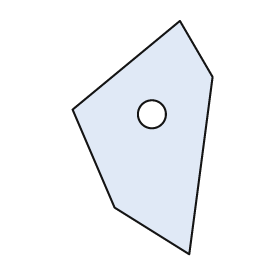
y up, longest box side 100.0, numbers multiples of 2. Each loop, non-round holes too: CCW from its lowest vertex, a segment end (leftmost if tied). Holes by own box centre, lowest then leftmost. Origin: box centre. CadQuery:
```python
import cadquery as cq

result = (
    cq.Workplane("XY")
    .moveTo(20.0, -50.0)
    .lineTo(30.0, 26.0)
    .lineTo(16.0, 50.0)
    .lineTo(-30.0, 12.0)
    .lineTo(-12.0, -30.0)
    .close()
    .moveTo(4.0, 10.0)
    .circle(6.0)
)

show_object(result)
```